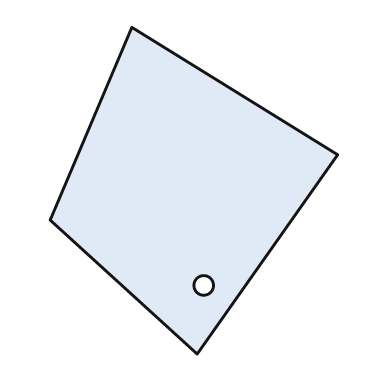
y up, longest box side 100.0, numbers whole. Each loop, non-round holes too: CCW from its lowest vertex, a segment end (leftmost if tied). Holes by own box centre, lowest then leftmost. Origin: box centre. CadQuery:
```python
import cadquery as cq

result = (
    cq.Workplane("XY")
    .moveTo(1.0, -50.0)
    .lineTo(44.0, 11.0)
    .lineTo(-19.0, 50.0)
    .lineTo(-44.0, -9.0)
    .close()
    .moveTo(3.0, -29.0)
    .circle(3.0)
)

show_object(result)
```